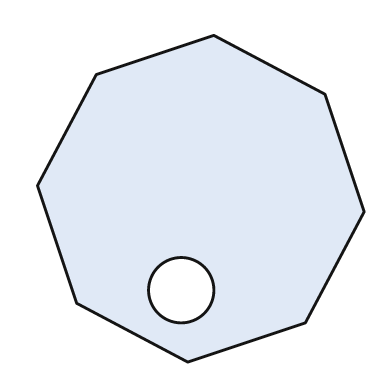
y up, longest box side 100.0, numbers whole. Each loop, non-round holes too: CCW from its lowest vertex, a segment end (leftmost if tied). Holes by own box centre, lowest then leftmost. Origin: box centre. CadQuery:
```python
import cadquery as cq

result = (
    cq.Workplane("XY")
    .moveTo(-4.0, -50.0)
    .lineTo(32.0, -38.0)
    .lineTo(50.0, -4.0)
    .lineTo(38.0, 32.0)
    .lineTo(4.0, 50.0)
    .lineTo(-32.0, 38.0)
    .lineTo(-50.0, 4.0)
    .lineTo(-38.0, -32.0)
    .close()
    .moveTo(-6.0, -28.0)
    .circle(10.0)
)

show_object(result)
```